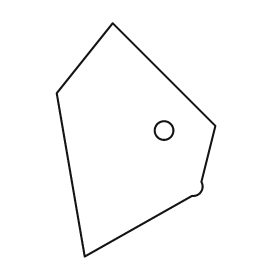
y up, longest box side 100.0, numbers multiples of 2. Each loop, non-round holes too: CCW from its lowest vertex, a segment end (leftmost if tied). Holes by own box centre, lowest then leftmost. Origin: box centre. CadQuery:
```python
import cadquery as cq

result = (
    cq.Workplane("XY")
    .moveTo(-22.0, -50.0)
    .lineTo(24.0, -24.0)
    .threePointArc((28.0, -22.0), (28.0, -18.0))
    .lineTo(34.0, 6.0)
    .lineTo(-10.0, 50.0)
    .lineTo(-34.0, 20.0)
    .close()
    .moveTo(12.0, 4.0)
    .circle(4.0)
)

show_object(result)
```